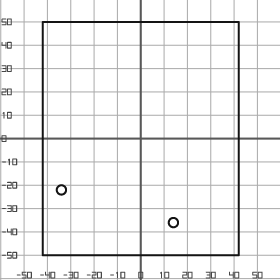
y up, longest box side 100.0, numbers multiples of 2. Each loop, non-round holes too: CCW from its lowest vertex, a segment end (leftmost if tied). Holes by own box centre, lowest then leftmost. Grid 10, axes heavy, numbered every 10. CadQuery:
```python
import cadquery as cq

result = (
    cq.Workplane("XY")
    .moveTo(-42.0, -50.0)
    .lineTo(42.0, -50.0)
    .lineTo(42.0, 50.0)
    .lineTo(-42.0, 50.0)
    .close()
    .moveTo(14.0, -36.0)
    .circle(2.0)
    .moveTo(-34.0, -22.0)
    .circle(2.0)
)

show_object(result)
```